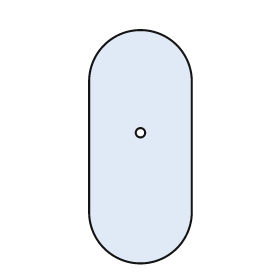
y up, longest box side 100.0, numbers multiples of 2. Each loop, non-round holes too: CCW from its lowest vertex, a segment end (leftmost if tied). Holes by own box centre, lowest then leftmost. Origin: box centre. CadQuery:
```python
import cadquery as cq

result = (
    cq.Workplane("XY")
    .moveTo(-22.0, -28.0)
    .threePointArc((0.0, -50.0), (22.0, -28.0))
    .lineTo(22.0, 28.0)
    .threePointArc((0.0, 50.0), (-22.0, 28.0))
    .close()
    .moveTo(0.0, 6.0)
    .circle(2.0)
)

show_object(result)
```